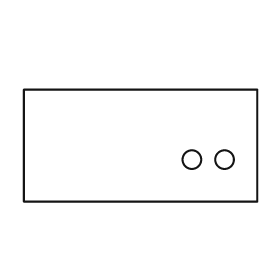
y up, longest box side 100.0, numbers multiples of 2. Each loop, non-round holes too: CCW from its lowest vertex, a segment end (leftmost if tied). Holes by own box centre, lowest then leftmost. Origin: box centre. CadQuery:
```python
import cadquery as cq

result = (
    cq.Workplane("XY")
    .moveTo(-50.0, -24.0)
    .lineTo(50.0, -24.0)
    .lineTo(50.0, 24.0)
    .lineTo(-50.0, 24.0)
    .close()
    .moveTo(22.0, -6.0)
    .circle(4.0)
    .moveTo(36.0, -6.0)
    .circle(4.0)
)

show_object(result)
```